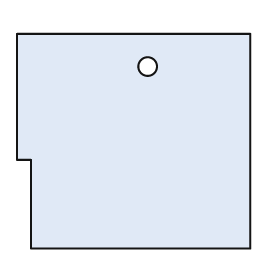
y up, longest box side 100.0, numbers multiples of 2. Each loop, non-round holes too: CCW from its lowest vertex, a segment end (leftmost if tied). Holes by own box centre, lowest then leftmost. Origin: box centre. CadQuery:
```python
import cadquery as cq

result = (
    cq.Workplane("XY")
    .moveTo(-44.0, -46.0)
    .lineTo(50.0, -46.0)
    .lineTo(50.0, 46.0)
    .lineTo(-50.0, 46.0)
    .lineTo(-50.0, -8.0)
    .lineTo(-44.0, -8.0)
    .close()
    .moveTo(6.0, 32.0)
    .circle(4.0)
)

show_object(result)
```